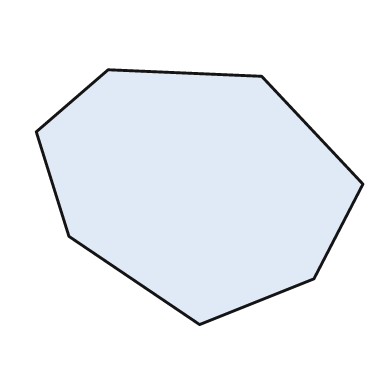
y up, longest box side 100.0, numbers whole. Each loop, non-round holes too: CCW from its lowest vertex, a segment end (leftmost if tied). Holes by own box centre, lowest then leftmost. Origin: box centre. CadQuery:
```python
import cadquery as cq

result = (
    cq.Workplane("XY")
    .moveTo(0.0, -39.0)
    .lineTo(35.0, -25.0)
    .lineTo(50.0, 4.0)
    .lineTo(19.0, 37.0)
    .lineTo(-28.0, 39.0)
    .lineTo(-50.0, 20.0)
    .lineTo(-40.0, -12.0)
    .close()
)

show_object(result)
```